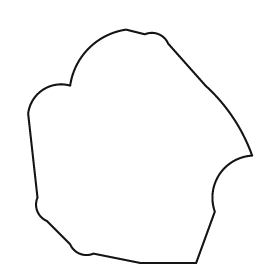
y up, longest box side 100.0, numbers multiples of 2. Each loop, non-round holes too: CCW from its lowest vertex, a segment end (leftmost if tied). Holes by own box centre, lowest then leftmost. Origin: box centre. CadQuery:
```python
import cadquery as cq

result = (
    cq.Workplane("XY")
    .moveTo(0.0, -50.0)
    .lineTo(24.0, -50.0)
    .lineTo(32.0, -28.0)
    .threePointArc((34.0, -12.0), (48.0, -4.0))
    .threePointArc((40.0, 12.0), (28.0, 26.0))
    .lineTo(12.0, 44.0)
    .threePointArc((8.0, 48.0), (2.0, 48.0))
    .lineTo(-6.0, 50.0)
    .threePointArc((-22.0, 42.0), (-30.0, 26.0))
    .threePointArc((-42.0, 24.0), (-48.0, 14.0))
    .lineTo(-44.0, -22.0)
    .threePointArc((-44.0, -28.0), (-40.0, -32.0))
    .lineTo(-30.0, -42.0)
    .threePointArc((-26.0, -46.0), (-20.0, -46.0))
    .close()
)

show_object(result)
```